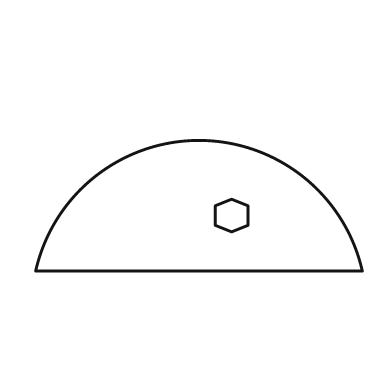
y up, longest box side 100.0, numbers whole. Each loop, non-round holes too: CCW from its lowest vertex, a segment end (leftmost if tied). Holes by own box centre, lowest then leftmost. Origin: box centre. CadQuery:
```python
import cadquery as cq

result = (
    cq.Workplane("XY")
    .moveTo(-50.0, -20.0)
    .lineTo(50.0, -20.0)
    .threePointArc((0.0, 20.0), (-50.0, -20.0))
    .close()
    .moveTo(10.0, -8.0)
    .lineTo(15.0, -6.0)
    .lineTo(15.0, 0.0)
    .lineTo(10.0, 2.0)
    .lineTo(5.0, 0.0)
    .lineTo(5.0, -6.0)
    .close()
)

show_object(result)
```